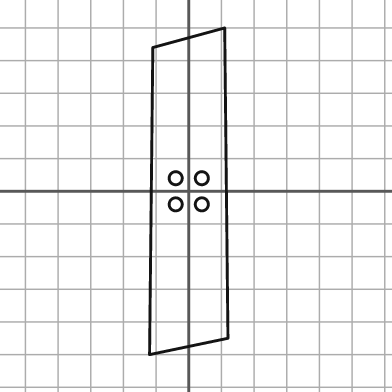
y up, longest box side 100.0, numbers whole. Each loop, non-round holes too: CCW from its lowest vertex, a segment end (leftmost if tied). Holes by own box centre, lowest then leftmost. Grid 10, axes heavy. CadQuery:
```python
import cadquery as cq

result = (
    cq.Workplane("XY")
    .moveTo(-12.0, -50.0)
    .lineTo(12.0, -45.0)
    .lineTo(11.0, 50.0)
    .lineTo(-11.0, 44.0)
    .close()
    .moveTo(-4.0, -4.0)
    .circle(2.0)
    .moveTo(4.0, -4.0)
    .circle(2.0)
    .moveTo(-4.0, 4.0)
    .circle(2.0)
    .moveTo(4.0, 4.0)
    .circle(2.0)
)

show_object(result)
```